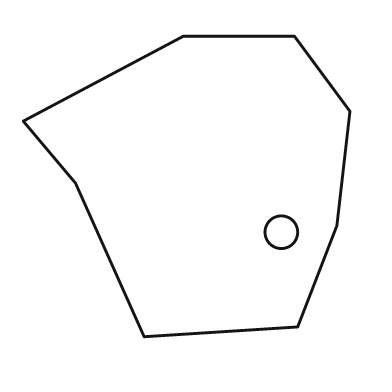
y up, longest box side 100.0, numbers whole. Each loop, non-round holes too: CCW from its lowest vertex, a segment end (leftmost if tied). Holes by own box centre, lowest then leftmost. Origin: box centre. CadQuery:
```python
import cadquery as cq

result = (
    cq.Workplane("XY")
    .moveTo(-13.0, -46.0)
    .lineTo(34.0, -43.0)
    .lineTo(46.0, -12.0)
    .lineTo(50.0, 23.0)
    .lineTo(33.0, 46.0)
    .lineTo(-1.0, 46.0)
    .lineTo(-50.0, 20.0)
    .lineTo(-34.0, 1.0)
    .close()
    .moveTo(29.0, -14.0)
    .circle(5.0)
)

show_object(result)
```